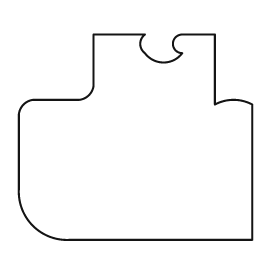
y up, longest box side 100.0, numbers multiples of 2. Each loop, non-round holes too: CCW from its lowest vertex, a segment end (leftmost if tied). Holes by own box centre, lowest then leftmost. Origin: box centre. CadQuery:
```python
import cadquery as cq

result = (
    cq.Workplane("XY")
    .moveTo(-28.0, -44.0)
    .lineTo(50.0, -44.0)
    .lineTo(50.0, 14.0)
    .threePointArc((42.0, 16.0), (34.0, 14.0))
    .lineTo(34.0, 44.0)
    .lineTo(20.0, 44.0)
    .threePointArc((16.0, 40.0), (20.0, 36.0))
    .threePointArc((12.0, 32.0), (4.0, 36.0))
    .threePointArc((2.0, 40.0), (4.0, 44.0))
    .lineTo(-18.0, 44.0)
    .lineTo(-18.0, 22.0)
    .threePointArc((-20.0, 18.0), (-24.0, 16.0))
    .lineTo(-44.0, 16.0)
    .threePointArc((-48.0, 14.0), (-50.0, 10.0))
    .lineTo(-50.0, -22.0)
    .threePointArc((-44.0, -38.0), (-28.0, -44.0))
    .close()
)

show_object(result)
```